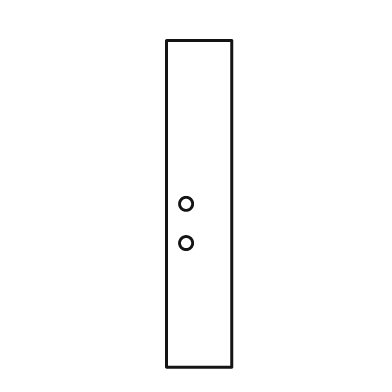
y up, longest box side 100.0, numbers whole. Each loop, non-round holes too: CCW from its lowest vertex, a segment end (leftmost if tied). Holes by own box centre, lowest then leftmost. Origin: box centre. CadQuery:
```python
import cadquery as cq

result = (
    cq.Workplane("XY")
    .moveTo(-10.0, -50.0)
    .lineTo(10.0, -50.0)
    .lineTo(10.0, 50.0)
    .lineTo(-10.0, 50.0)
    .close()
    .moveTo(-4.0, -12.0)
    .circle(2.0)
    .moveTo(-4.0, 0.0)
    .circle(2.0)
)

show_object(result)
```